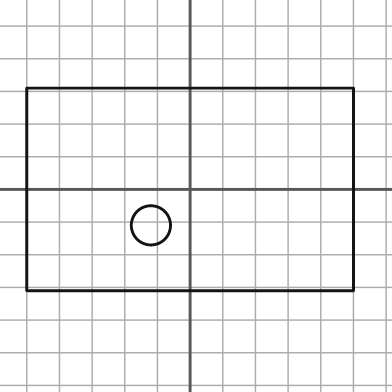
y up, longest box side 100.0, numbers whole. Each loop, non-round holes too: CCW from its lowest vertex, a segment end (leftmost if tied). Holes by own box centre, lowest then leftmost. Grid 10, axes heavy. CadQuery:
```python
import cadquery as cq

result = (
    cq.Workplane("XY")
    .moveTo(-50.0, -31.0)
    .lineTo(50.0, -31.0)
    .lineTo(50.0, 31.0)
    .lineTo(-50.0, 31.0)
    .close()
    .moveTo(-12.0, -11.0)
    .circle(6.0)
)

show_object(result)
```